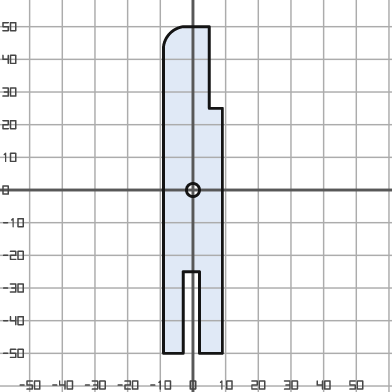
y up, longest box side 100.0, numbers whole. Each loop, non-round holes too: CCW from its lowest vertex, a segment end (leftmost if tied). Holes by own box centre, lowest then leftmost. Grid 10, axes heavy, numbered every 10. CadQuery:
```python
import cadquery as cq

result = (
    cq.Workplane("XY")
    .moveTo(-9.0, -50.0)
    .lineTo(-3.0, -50.0)
    .lineTo(-3.0, -25.0)
    .lineTo(2.0, -25.0)
    .lineTo(2.0, -50.0)
    .lineTo(9.0, -50.0)
    .lineTo(9.0, 25.0)
    .lineTo(5.0, 25.0)
    .lineTo(5.0, 50.0)
    .lineTo(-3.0, 50.0)
    .threePointArc((-7.0, 48.0), (-9.0, 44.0))
    .close()
    .moveTo(0.0, 0.0)
    .circle(2.0)
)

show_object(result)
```